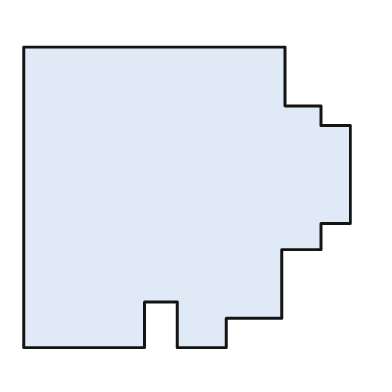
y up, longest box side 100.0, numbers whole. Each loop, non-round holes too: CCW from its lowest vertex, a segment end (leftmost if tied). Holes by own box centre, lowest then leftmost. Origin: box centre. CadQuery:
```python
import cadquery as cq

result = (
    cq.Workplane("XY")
    .moveTo(-50.0, -46.0)
    .lineTo(-13.0, -46.0)
    .lineTo(-13.0, -32.0)
    .lineTo(-3.0, -32.0)
    .lineTo(-3.0, -46.0)
    .lineTo(12.0, -46.0)
    .lineTo(12.0, -37.0)
    .lineTo(29.0, -37.0)
    .lineTo(29.0, -16.0)
    .lineTo(41.0, -16.0)
    .lineTo(41.0, -8.0)
    .lineTo(50.0, -8.0)
    .lineTo(50.0, 22.0)
    .lineTo(41.0, 22.0)
    .lineTo(41.0, 28.0)
    .lineTo(30.0, 28.0)
    .lineTo(30.0, 46.0)
    .lineTo(-50.0, 46.0)
    .close()
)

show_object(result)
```